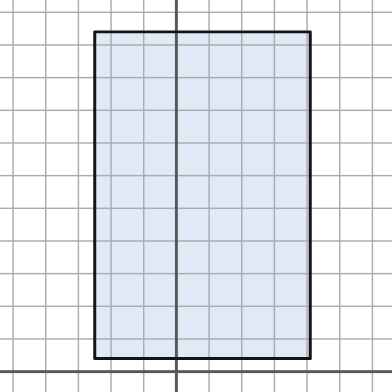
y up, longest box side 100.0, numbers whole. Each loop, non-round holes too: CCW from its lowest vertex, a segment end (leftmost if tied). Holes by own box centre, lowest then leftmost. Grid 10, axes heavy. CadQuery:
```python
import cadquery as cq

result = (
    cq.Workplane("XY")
    .moveTo(-25.0, 4.0)
    .lineTo(41.0, 4.0)
    .lineTo(41.0, 104.0)
    .lineTo(-25.0, 104.0)
    .close()
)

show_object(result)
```